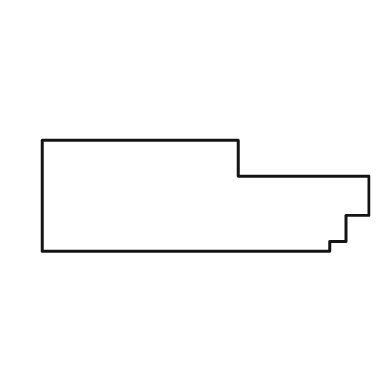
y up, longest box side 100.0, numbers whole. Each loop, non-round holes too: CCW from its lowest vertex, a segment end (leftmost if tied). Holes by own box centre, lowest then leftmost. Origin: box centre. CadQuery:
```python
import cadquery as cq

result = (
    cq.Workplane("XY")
    .moveTo(-50.0, -17.0)
    .lineTo(38.0, -17.0)
    .lineTo(38.0, -14.0)
    .lineTo(43.0, -14.0)
    .lineTo(43.0, -6.0)
    .lineTo(50.0, -6.0)
    .lineTo(50.0, 6.0)
    .lineTo(10.0, 6.0)
    .lineTo(10.0, 17.0)
    .lineTo(-50.0, 17.0)
    .close()
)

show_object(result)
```